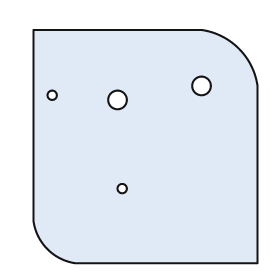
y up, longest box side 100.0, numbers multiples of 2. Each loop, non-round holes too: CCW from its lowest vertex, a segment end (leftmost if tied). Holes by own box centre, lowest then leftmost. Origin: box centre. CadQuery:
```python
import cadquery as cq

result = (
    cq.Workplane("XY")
    .moveTo(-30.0, -50.0)
    .lineTo(48.0, -50.0)
    .lineTo(48.0, 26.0)
    .threePointArc((40.0, 42.0), (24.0, 50.0))
    .lineTo(-48.0, 50.0)
    .lineTo(-48.0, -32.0)
    .threePointArc((-42.0, -44.0), (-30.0, -50.0))
    .close()
    .moveTo(-10.0, -18.0)
    .circle(2.0)
    .moveTo(-12.0, 20.0)
    .circle(4.0)
    .moveTo(-40.0, 22.0)
    .circle(2.0)
    .moveTo(24.0, 26.0)
    .circle(4.0)
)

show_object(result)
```